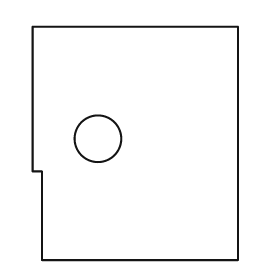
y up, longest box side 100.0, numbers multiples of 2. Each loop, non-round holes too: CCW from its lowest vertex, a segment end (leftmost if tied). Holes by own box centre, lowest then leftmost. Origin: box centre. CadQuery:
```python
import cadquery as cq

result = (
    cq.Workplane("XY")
    .moveTo(-40.0, -50.0)
    .lineTo(44.0, -50.0)
    .lineTo(44.0, 50.0)
    .lineTo(-44.0, 50.0)
    .lineTo(-44.0, -12.0)
    .lineTo(-40.0, -12.0)
    .close()
    .moveTo(-16.0, 2.0)
    .circle(10.0)
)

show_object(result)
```